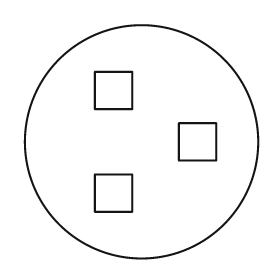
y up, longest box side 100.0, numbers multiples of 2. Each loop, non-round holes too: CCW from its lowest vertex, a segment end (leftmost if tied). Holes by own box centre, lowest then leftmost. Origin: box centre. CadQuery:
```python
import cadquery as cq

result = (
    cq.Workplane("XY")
    .moveTo(0.0, 0.0)
    .circle(50.0)
    .moveTo(-20.0, -30.0)
    .lineTo(-4.0, -30.0)
    .lineTo(-4.0, -14.0)
    .lineTo(-20.0, -14.0)
    .close()
    .moveTo(16.0, -8.0)
    .lineTo(32.0, -8.0)
    .lineTo(32.0, 8.0)
    .lineTo(16.0, 8.0)
    .close()
    .moveTo(-20.0, 14.0)
    .lineTo(-4.0, 14.0)
    .lineTo(-4.0, 30.0)
    .lineTo(-20.0, 30.0)
    .close()
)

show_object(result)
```